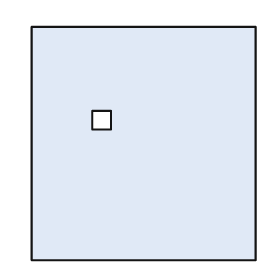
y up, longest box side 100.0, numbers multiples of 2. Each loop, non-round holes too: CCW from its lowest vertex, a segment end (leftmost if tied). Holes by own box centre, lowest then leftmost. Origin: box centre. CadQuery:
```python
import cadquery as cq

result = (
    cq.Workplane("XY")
    .moveTo(-48.0, -50.0)
    .lineTo(48.0, -50.0)
    .lineTo(48.0, 50.0)
    .lineTo(-48.0, 50.0)
    .close()
    .moveTo(-22.0, 6.0)
    .lineTo(-14.0, 6.0)
    .lineTo(-14.0, 14.0)
    .lineTo(-22.0, 14.0)
    .close()
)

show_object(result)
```